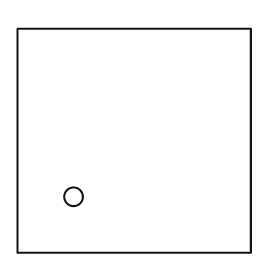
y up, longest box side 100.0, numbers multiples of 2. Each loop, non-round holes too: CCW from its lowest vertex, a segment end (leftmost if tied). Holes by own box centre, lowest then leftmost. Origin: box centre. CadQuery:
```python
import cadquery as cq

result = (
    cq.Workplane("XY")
    .moveTo(-50.0, -48.0)
    .lineTo(50.0, -48.0)
    .lineTo(50.0, 48.0)
    .lineTo(-50.0, 48.0)
    .close()
    .moveTo(-26.0, -24.0)
    .circle(4.0)
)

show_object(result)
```